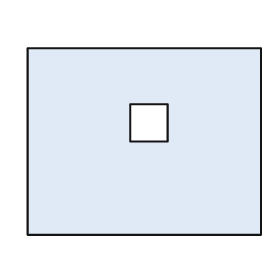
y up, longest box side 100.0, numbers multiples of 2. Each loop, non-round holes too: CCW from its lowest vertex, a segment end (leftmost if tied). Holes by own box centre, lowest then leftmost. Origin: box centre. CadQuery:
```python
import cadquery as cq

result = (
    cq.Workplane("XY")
    .moveTo(-50.0, -40.0)
    .lineTo(50.0, -40.0)
    .lineTo(50.0, 40.0)
    .lineTo(-50.0, 40.0)
    .close()
    .moveTo(-6.0, 0.0)
    .lineTo(10.0, 0.0)
    .lineTo(10.0, 16.0)
    .lineTo(-6.0, 16.0)
    .close()
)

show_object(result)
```